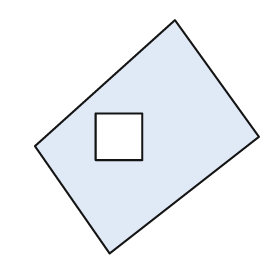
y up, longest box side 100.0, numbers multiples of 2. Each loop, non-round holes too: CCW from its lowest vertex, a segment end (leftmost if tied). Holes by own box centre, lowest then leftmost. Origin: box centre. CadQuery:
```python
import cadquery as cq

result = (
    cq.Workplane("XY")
    .moveTo(-16.0, -50.0)
    .lineTo(48.0, 0.0)
    .lineTo(12.0, 50.0)
    .lineTo(-48.0, -4.0)
    .close()
    .moveTo(-22.0, -10.0)
    .lineTo(-2.0, -10.0)
    .lineTo(-2.0, 10.0)
    .lineTo(-22.0, 10.0)
    .close()
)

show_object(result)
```